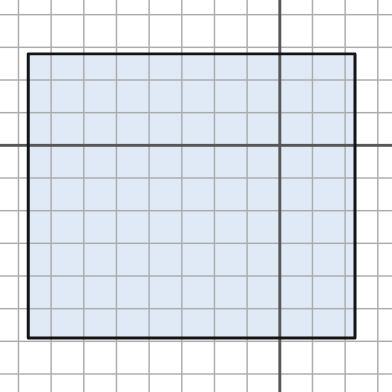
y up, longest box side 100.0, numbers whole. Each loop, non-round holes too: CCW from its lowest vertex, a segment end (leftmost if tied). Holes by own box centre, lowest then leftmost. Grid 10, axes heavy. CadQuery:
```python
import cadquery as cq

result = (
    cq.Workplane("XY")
    .moveTo(-77.0, -59.0)
    .lineTo(23.0, -59.0)
    .lineTo(23.0, 28.0)
    .lineTo(-77.0, 28.0)
    .close()
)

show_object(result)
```